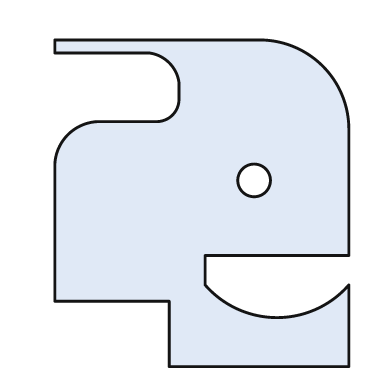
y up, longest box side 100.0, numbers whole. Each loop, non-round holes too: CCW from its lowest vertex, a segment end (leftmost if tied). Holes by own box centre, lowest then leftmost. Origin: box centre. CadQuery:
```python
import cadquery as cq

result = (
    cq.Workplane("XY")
    .moveTo(-10.0, -50.0)
    .lineTo(45.0, -50.0)
    .lineTo(45.0, -25.0)
    .threePointArc((23.0, -35.0), (1.0, -25.0))
    .lineTo(1.0, -16.0)
    .lineTo(45.0, -16.0)
    .lineTo(45.0, 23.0)
    .threePointArc((37.0, 42.0), (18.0, 50.0))
    .lineTo(-45.0, 50.0)
    .lineTo(-45.0, 46.0)
    .lineTo(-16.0, 46.0)
    .threePointArc((-10.0, 43.0), (-7.0, 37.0))
    .lineTo(-7.0, 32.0)
    .threePointArc((-9.0, 27.0), (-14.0, 25.0))
    .lineTo(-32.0, 25.0)
    .threePointArc((-41.0, 21.0), (-45.0, 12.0))
    .lineTo(-45.0, -30.0)
    .lineTo(-10.0, -30.0)
    .close()
    .moveTo(16.0, 7.0)
    .circle(5.0)
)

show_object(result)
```